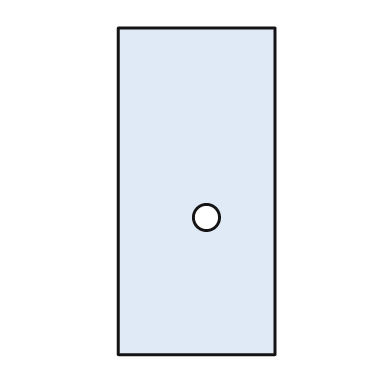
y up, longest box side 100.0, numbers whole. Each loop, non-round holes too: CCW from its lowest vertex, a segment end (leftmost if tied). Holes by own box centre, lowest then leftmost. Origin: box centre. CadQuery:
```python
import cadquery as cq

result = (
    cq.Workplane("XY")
    .moveTo(-24.0, -50.0)
    .lineTo(24.0, -50.0)
    .lineTo(24.0, 50.0)
    .lineTo(-24.0, 50.0)
    .close()
    .moveTo(3.0, -8.0)
    .circle(4.0)
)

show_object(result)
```